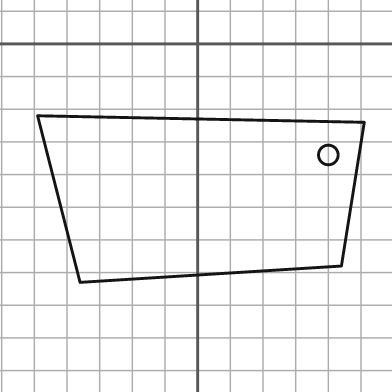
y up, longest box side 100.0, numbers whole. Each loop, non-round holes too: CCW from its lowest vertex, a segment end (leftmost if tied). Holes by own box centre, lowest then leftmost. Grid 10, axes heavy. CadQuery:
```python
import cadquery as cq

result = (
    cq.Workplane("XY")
    .moveTo(-36.0, -73.0)
    .lineTo(44.0, -68.0)
    .lineTo(51.0, -24.0)
    .lineTo(-49.0, -22.0)
    .close()
    .moveTo(40.0, -34.0)
    .circle(3.0)
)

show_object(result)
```